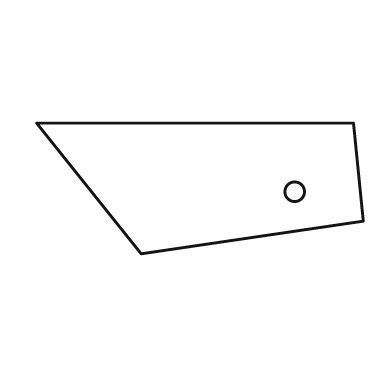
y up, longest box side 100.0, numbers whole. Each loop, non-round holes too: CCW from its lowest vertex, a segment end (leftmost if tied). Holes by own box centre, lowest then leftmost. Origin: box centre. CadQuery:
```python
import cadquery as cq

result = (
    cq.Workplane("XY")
    .moveTo(-18.0, -20.0)
    .lineTo(50.0, -10.0)
    .lineTo(47.0, 20.0)
    .lineTo(-50.0, 20.0)
    .close()
    .moveTo(29.0, -1.0)
    .circle(3.0)
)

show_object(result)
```